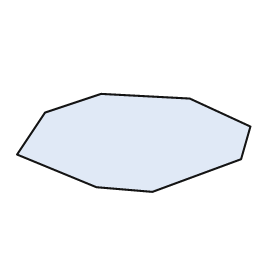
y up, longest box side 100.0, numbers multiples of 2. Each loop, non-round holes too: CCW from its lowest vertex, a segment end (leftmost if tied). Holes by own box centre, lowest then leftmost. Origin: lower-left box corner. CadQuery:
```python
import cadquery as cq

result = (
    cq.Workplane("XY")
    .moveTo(58.0, 0.0)
    .lineTo(96.0, 14.0)
    .lineTo(100.0, 28.0)
    .lineTo(74.0, 40.0)
    .lineTo(36.0, 42.0)
    .lineTo(12.0, 34.0)
    .lineTo(0.0, 16.0)
    .lineTo(34.0, 2.0)
    .close()
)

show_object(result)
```